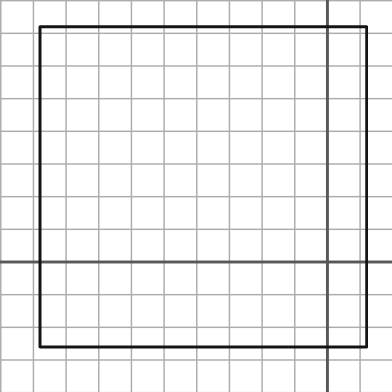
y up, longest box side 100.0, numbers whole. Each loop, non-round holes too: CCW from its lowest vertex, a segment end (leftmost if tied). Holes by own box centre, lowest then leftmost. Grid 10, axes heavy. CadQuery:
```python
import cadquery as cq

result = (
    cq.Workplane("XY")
    .moveTo(-88.0, -26.0)
    .lineTo(12.0, -26.0)
    .lineTo(12.0, 72.0)
    .lineTo(-88.0, 72.0)
    .close()
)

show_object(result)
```